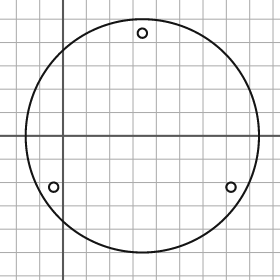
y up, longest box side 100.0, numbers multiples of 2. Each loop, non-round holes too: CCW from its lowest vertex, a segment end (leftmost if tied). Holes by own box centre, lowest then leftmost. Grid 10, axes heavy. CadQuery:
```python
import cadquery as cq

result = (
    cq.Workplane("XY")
    .moveTo(34.0, 0.0)
    .circle(50.0)
    .moveTo(-4.0, -22.0)
    .circle(2.0)
    .moveTo(72.0, -22.0)
    .circle(2.0)
    .moveTo(34.0, 44.0)
    .circle(2.0)
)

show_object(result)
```